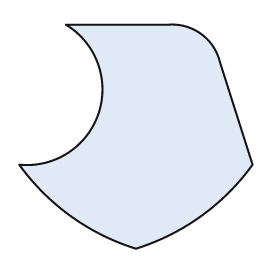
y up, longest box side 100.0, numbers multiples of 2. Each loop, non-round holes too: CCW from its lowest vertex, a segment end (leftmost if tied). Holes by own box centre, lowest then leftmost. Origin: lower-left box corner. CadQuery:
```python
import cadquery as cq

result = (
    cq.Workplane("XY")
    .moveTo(50.0, 0.0)
    .threePointArc((78.0, 14.0), (100.0, 36.0))
    .lineTo(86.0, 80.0)
    .threePointArc((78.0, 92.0), (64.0, 96.0))
    .lineTo(20.0, 96.0)
    .threePointArc((34.0, 58.0), (0.0, 36.0))
    .threePointArc((22.0, 14.0), (50.0, 0.0))
    .close()
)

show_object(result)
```